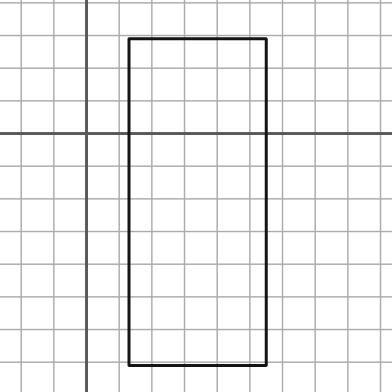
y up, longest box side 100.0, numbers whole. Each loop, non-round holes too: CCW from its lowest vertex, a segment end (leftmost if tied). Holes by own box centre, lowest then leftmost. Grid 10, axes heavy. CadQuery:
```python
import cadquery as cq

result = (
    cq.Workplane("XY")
    .moveTo(13.0, -71.0)
    .lineTo(55.0, -71.0)
    .lineTo(55.0, 29.0)
    .lineTo(13.0, 29.0)
    .close()
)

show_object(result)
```